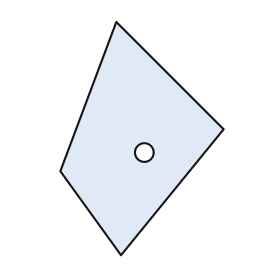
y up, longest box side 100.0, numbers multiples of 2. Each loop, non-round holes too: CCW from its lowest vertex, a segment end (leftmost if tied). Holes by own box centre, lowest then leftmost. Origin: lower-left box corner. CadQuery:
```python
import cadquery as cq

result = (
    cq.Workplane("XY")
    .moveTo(26.0, 0.0)
    .lineTo(70.0, 54.0)
    .lineTo(24.0, 100.0)
    .lineTo(0.0, 36.0)
    .close()
    .moveTo(36.0, 44.0)
    .circle(4.0)
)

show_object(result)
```